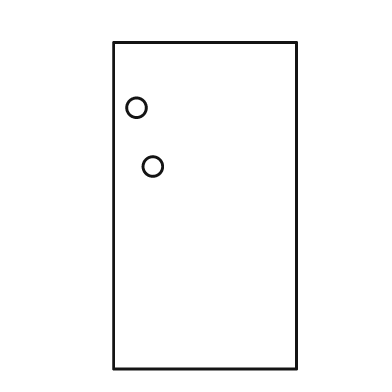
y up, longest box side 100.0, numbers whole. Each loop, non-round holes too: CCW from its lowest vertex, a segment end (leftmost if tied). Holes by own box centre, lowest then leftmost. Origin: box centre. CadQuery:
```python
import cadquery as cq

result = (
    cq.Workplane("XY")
    .moveTo(-28.0, -50.0)
    .lineTo(28.0, -50.0)
    .lineTo(28.0, 50.0)
    .lineTo(-28.0, 50.0)
    .close()
    .moveTo(-16.0, 12.0)
    .circle(3.0)
    .moveTo(-21.0, 30.0)
    .circle(3.0)
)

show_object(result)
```